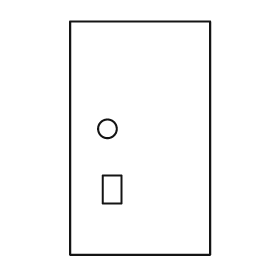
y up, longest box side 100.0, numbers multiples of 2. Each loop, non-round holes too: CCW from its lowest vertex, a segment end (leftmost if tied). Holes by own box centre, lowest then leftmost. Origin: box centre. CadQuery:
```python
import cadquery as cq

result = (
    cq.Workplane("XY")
    .moveTo(-30.0, -50.0)
    .lineTo(30.0, -50.0)
    .lineTo(30.0, 50.0)
    .lineTo(-30.0, 50.0)
    .close()
    .moveTo(-16.0, -28.0)
    .lineTo(-8.0, -28.0)
    .lineTo(-8.0, -16.0)
    .lineTo(-16.0, -16.0)
    .close()
    .moveTo(-14.0, 4.0)
    .circle(4.0)
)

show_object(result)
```